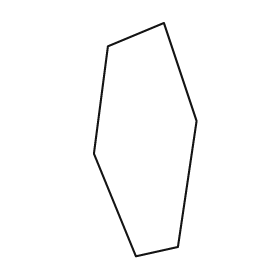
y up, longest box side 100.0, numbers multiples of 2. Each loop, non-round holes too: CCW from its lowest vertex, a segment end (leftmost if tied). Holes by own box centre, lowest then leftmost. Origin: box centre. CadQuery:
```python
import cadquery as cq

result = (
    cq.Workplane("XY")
    .moveTo(-4.0, -50.0)
    .lineTo(14.0, -46.0)
    .lineTo(22.0, 8.0)
    .lineTo(8.0, 50.0)
    .lineTo(-16.0, 40.0)
    .lineTo(-22.0, -6.0)
    .close()
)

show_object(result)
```